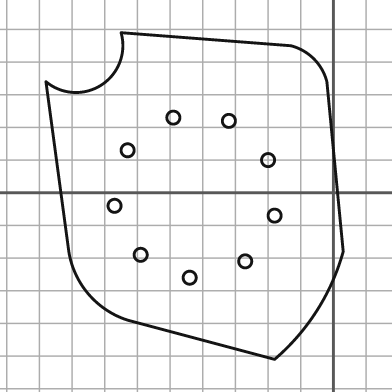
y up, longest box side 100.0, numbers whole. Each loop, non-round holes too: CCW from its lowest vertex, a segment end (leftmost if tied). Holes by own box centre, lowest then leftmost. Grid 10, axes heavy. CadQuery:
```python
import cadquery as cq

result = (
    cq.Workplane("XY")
    .moveTo(-18.0, -51.0)
    .threePointArc((-5.0, -36.0), (3.0, -18.0))
    .lineTo(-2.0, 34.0)
    .threePointArc((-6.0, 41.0), (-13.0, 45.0))
    .lineTo(-65.0, 49.0)
    .threePointArc((-71.0, 33.0), (-88.0, 34.0))
    .lineTo(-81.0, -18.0)
    .threePointArc((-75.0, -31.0), (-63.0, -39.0))
    .close()
    .moveTo(-44.0, -26.0)
    .circle(2.0)
    .moveTo(-27.0, -21.0)
    .circle(2.0)
    .moveTo(-59.0, -19.0)
    .circle(2.0)
    .moveTo(-18.0, -7.0)
    .circle(2.0)
    .moveTo(-67.0, -4.0)
    .circle(2.0)
    .moveTo(-20.0, 10.0)
    .circle(2.0)
    .moveTo(-63.0, 13.0)
    .circle(2.0)
    .moveTo(-32.0, 22.0)
    .circle(2.0)
    .moveTo(-49.0, 23.0)
    .circle(2.0)
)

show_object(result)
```